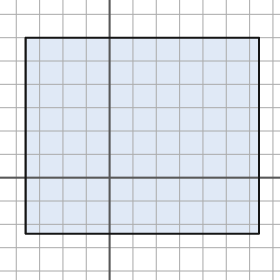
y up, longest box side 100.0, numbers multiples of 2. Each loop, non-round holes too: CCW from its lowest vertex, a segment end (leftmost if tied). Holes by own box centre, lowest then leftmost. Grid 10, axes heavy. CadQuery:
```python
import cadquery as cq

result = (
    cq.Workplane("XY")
    .moveTo(-36.0, -24.0)
    .lineTo(64.0, -24.0)
    .lineTo(64.0, 60.0)
    .lineTo(-36.0, 60.0)
    .close()
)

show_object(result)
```